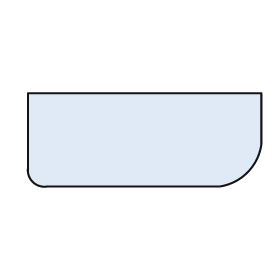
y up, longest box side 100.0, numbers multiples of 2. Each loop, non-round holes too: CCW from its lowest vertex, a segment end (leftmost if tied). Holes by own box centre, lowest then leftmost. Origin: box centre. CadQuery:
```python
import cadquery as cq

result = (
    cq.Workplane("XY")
    .moveTo(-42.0, -20.0)
    .lineTo(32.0, -20.0)
    .threePointArc((44.0, -14.0), (50.0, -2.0))
    .lineTo(50.0, 20.0)
    .lineTo(-50.0, 20.0)
    .lineTo(-50.0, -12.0)
    .threePointArc((-48.0, -18.0), (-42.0, -20.0))
    .close()
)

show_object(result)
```